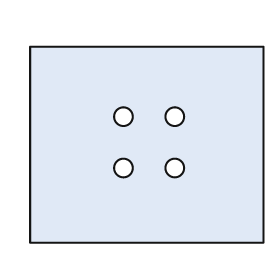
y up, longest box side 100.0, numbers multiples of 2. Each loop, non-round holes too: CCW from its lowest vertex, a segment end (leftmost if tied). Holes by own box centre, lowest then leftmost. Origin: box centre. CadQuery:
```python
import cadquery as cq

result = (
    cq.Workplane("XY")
    .moveTo(-50.0, -42.0)
    .lineTo(50.0, -42.0)
    .lineTo(50.0, 42.0)
    .lineTo(-50.0, 42.0)
    .close()
    .moveTo(-10.0, -10.0)
    .circle(4.0)
    .moveTo(12.0, -10.0)
    .circle(4.0)
    .moveTo(-10.0, 12.0)
    .circle(4.0)
    .moveTo(12.0, 12.0)
    .circle(4.0)
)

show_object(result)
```